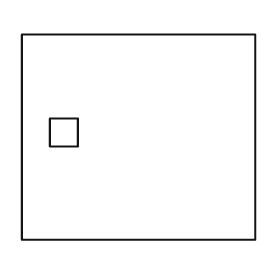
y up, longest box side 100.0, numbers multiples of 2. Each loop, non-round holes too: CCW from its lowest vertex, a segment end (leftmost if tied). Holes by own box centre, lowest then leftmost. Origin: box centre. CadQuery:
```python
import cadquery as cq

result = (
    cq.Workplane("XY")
    .moveTo(-50.0, -44.0)
    .lineTo(50.0, -44.0)
    .lineTo(50.0, 44.0)
    .lineTo(-50.0, 44.0)
    .close()
    .moveTo(-38.0, -4.0)
    .lineTo(-26.0, -4.0)
    .lineTo(-26.0, 8.0)
    .lineTo(-38.0, 8.0)
    .close()
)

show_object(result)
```